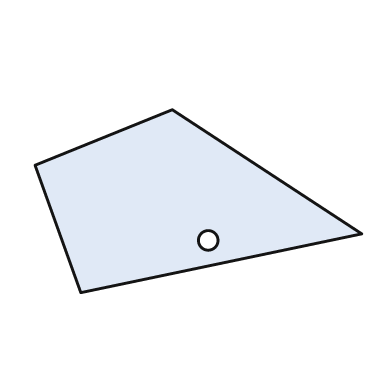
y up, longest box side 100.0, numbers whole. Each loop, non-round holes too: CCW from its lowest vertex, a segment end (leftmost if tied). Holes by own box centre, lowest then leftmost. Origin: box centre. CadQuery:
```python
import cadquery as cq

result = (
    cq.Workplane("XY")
    .moveTo(-36.0, -28.0)
    .lineTo(50.0, -10.0)
    .lineTo(-8.0, 28.0)
    .lineTo(-50.0, 11.0)
    .close()
    .moveTo(3.0, -12.0)
    .circle(3.0)
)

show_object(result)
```